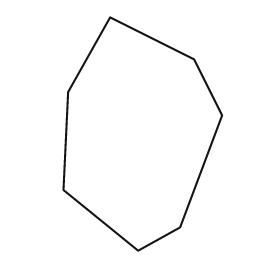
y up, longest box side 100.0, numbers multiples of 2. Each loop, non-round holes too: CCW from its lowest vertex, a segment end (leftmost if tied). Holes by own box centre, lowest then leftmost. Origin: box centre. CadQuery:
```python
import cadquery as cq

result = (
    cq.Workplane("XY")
    .moveTo(-2.0, -50.0)
    .lineTo(16.0, -40.0)
    .lineTo(34.0, 8.0)
    .lineTo(22.0, 32.0)
    .lineTo(-14.0, 50.0)
    .lineTo(-32.0, 18.0)
    .lineTo(-34.0, -24.0)
    .close()
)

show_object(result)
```